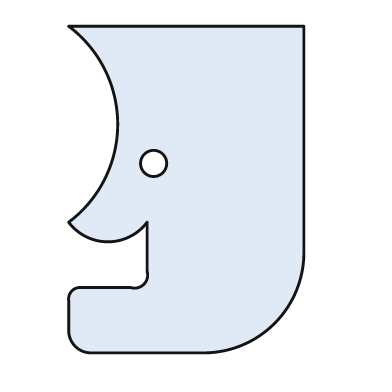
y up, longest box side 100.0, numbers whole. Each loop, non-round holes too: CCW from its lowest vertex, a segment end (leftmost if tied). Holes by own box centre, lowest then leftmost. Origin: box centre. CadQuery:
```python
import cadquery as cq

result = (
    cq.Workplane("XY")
    .moveTo(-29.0, -50.0)
    .lineTo(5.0, -50.0)
    .threePointArc((27.0, -41.0), (36.0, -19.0))
    .lineTo(36.0, 50.0)
    .lineTo(-36.0, 50.0)
    .threePointArc((-21.0, 20.0), (-36.0, -10.0))
    .threePointArc((-24.0, -16.0), (-12.0, -10.0))
    .lineTo(-12.0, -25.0)
    .threePointArc((-13.0, -29.0), (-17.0, -30.0))
    .lineTo(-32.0, -30.0)
    .threePointArc((-35.0, -31.0), (-36.0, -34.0))
    .lineTo(-36.0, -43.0)
    .threePointArc((-34.0, -48.0), (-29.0, -50.0))
    .close()
    .moveTo(-10.0, 8.0)
    .circle(4.0)
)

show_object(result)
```